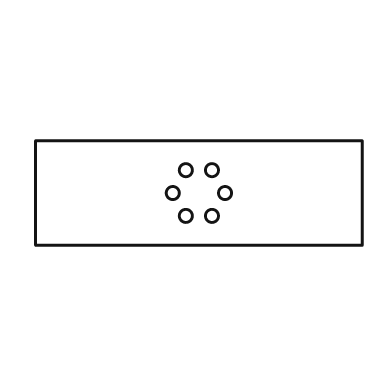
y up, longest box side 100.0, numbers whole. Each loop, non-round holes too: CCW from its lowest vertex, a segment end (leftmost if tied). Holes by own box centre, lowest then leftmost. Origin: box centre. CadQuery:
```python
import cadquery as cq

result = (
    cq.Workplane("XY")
    .moveTo(-50.0, -16.0)
    .lineTo(50.0, -16.0)
    .lineTo(50.0, 16.0)
    .lineTo(-50.0, 16.0)
    .close()
    .moveTo(-4.0, -7.0)
    .circle(2.0)
    .moveTo(4.0, -7.0)
    .circle(2.0)
    .moveTo(-8.0, 0.0)
    .circle(2.0)
    .moveTo(8.0, 0.0)
    .circle(2.0)
    .moveTo(-4.0, 7.0)
    .circle(2.0)
    .moveTo(4.0, 7.0)
    .circle(2.0)
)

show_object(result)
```